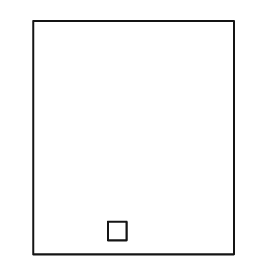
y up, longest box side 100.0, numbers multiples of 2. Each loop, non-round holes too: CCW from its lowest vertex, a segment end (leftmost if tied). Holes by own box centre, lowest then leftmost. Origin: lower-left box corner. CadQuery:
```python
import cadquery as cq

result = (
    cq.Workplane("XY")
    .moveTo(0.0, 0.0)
    .lineTo(86.0, 0.0)
    .lineTo(86.0, 100.0)
    .lineTo(0.0, 100.0)
    .close()
    .moveTo(32.0, 6.0)
    .lineTo(40.0, 6.0)
    .lineTo(40.0, 14.0)
    .lineTo(32.0, 14.0)
    .close()
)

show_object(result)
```